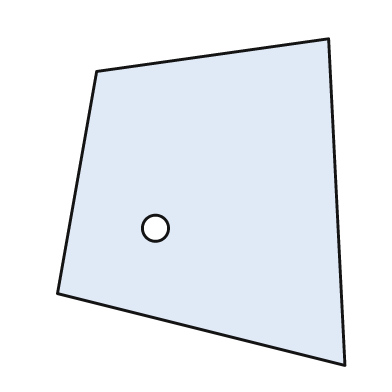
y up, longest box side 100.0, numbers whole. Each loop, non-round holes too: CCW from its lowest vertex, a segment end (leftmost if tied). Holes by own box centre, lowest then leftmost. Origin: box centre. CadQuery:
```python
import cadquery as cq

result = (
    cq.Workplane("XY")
    .moveTo(44.0, -50.0)
    .lineTo(39.0, 50.0)
    .lineTo(-32.0, 40.0)
    .lineTo(-44.0, -28.0)
    .close()
    .moveTo(-14.0, -8.0)
    .circle(4.0)
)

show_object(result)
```